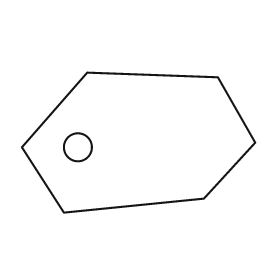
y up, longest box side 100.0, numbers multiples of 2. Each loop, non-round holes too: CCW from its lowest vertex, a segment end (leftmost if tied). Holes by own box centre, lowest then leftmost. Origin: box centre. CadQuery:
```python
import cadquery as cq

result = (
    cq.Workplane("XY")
    .moveTo(-32.0, -30.0)
    .lineTo(28.0, -24.0)
    .lineTo(50.0, 0.0)
    .lineTo(34.0, 28.0)
    .lineTo(-22.0, 30.0)
    .lineTo(-50.0, -2.0)
    .close()
    .moveTo(-26.0, -2.0)
    .circle(6.0)
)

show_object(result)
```